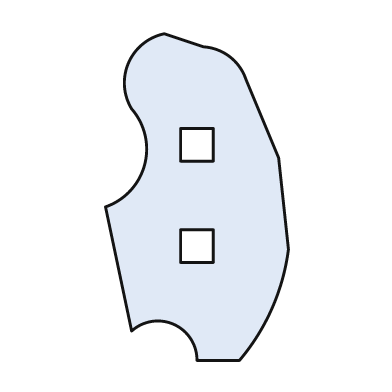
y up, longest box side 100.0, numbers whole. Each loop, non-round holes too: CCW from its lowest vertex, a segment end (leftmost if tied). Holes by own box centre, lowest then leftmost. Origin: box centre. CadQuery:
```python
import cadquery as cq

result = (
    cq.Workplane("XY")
    .moveTo(0.0, -50.0)
    .lineTo(13.0, -50.0)
    .threePointArc((23.0, -34.0), (28.0, -16.0))
    .lineTo(25.0, 12.0)
    .lineTo(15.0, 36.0)
    .threePointArc((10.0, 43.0), (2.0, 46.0))
    .lineTo(-10.0, 50.0)
    .threePointArc((-21.0, 41.0), (-20.0, 27.0))
    .threePointArc((-16.0, 10.0), (-28.0, -3.0))
    .lineTo(-20.0, -41.0)
    .threePointArc((-7.0, -39.0), (0.0, -50.0))
    .close()
    .moveTo(-5.0, -20.0)
    .lineTo(5.0, -20.0)
    .lineTo(5.0, -10.0)
    .lineTo(-5.0, -10.0)
    .close()
    .moveTo(-5.0, 11.0)
    .lineTo(5.0, 11.0)
    .lineTo(5.0, 21.0)
    .lineTo(-5.0, 21.0)
    .close()
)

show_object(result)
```